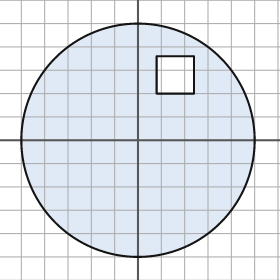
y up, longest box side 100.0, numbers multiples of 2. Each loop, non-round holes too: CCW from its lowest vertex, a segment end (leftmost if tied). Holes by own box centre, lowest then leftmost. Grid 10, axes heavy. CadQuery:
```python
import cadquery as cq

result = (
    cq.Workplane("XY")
    .moveTo(0.0, 0.0)
    .circle(50.0)
    .moveTo(8.0, 20.0)
    .lineTo(24.0, 20.0)
    .lineTo(24.0, 36.0)
    .lineTo(8.0, 36.0)
    .close()
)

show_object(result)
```